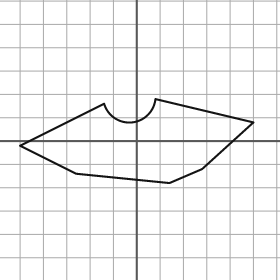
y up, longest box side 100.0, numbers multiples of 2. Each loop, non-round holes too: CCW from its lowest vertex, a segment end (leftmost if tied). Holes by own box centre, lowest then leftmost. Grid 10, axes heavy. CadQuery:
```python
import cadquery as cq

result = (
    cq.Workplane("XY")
    .moveTo(14.0, -18.0)
    .lineTo(28.0, -12.0)
    .lineTo(50.0, 8.0)
    .lineTo(8.0, 18.0)
    .threePointArc((-2.0, 8.0), (-14.0, 16.0))
    .lineTo(-50.0, -2.0)
    .lineTo(-26.0, -14.0)
    .close()
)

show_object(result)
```